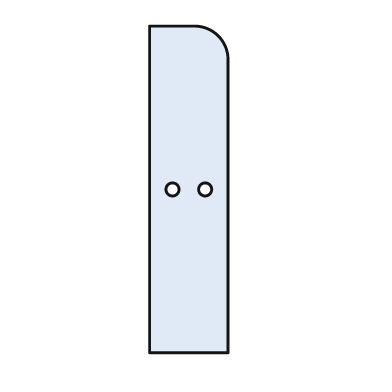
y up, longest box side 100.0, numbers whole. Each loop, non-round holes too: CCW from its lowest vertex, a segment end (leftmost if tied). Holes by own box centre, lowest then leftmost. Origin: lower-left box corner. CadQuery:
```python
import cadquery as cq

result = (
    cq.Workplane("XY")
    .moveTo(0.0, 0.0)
    .lineTo(24.0, 0.0)
    .lineTo(24.0, 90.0)
    .threePointArc((21.0, 97.0), (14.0, 100.0))
    .lineTo(0.0, 100.0)
    .close()
    .moveTo(7.0, 50.0)
    .circle(2.0)
    .moveTo(17.0, 50.0)
    .circle(2.0)
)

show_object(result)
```